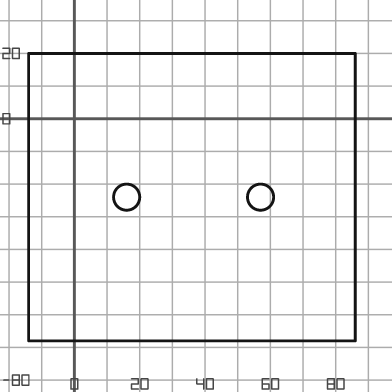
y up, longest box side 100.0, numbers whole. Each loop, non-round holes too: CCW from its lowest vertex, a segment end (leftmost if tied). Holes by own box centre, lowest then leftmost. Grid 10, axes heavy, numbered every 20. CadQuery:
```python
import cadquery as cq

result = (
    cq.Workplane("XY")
    .moveTo(-14.0, -68.0)
    .lineTo(86.0, -68.0)
    .lineTo(86.0, 20.0)
    .lineTo(-14.0, 20.0)
    .close()
    .moveTo(16.0, -24.0)
    .circle(4.0)
    .moveTo(57.0, -24.0)
    .circle(4.0)
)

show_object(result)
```